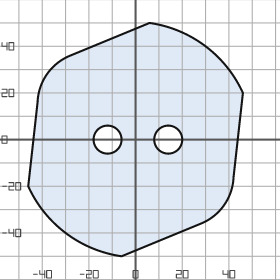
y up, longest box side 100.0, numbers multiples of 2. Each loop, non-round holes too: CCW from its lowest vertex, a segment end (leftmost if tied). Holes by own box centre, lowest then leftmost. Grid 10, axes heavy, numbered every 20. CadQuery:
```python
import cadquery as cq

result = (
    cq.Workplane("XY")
    .moveTo(-6.0, -50.0)
    .lineTo(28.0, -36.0)
    .threePointArc((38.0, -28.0), (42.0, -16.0))
    .lineTo(46.0, 20.0)
    .threePointArc((30.0, 40.0), (6.0, 50.0))
    .lineTo(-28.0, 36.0)
    .threePointArc((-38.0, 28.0), (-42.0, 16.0))
    .lineTo(-46.0, -20.0)
    .threePointArc((-30.0, -40.0), (-6.0, -50.0))
    .close()
    .moveTo(-12.0, 0.0)
    .circle(6.0)
    .moveTo(14.0, 0.0)
    .circle(6.0)
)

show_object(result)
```